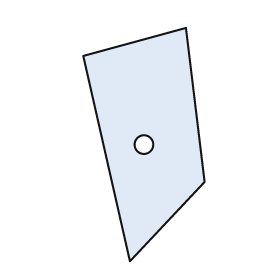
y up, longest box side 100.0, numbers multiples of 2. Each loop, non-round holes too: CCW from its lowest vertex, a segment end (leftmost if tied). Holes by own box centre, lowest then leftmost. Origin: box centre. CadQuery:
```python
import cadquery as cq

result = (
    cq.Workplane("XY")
    .moveTo(-6.0, -50.0)
    .lineTo(26.0, -16.0)
    .lineTo(18.0, 50.0)
    .lineTo(-26.0, 38.0)
    .close()
    .moveTo(0.0, 0.0)
    .circle(4.0)
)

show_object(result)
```